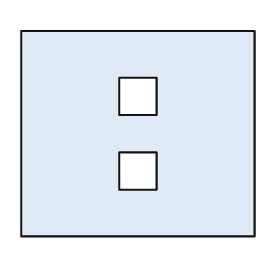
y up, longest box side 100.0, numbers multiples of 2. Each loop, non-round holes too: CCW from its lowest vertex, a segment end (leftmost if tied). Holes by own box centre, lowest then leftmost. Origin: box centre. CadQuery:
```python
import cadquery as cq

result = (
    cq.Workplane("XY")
    .moveTo(-50.0, -44.0)
    .lineTo(50.0, -44.0)
    .lineTo(50.0, 44.0)
    .lineTo(-50.0, 44.0)
    .close()
    .moveTo(-8.0, -24.0)
    .lineTo(8.0, -24.0)
    .lineTo(8.0, -8.0)
    .lineTo(-8.0, -8.0)
    .close()
    .moveTo(-8.0, 8.0)
    .lineTo(8.0, 8.0)
    .lineTo(8.0, 24.0)
    .lineTo(-8.0, 24.0)
    .close()
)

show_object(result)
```